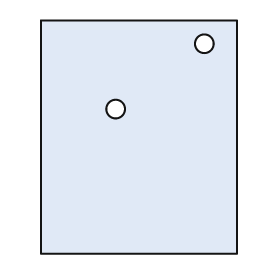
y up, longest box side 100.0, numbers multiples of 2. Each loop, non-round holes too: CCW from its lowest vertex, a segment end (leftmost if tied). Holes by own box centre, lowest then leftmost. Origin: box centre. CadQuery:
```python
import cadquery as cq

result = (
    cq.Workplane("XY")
    .moveTo(-42.0, -50.0)
    .lineTo(42.0, -50.0)
    .lineTo(42.0, 50.0)
    .lineTo(-42.0, 50.0)
    .close()
    .moveTo(-10.0, 12.0)
    .circle(4.0)
    .moveTo(28.0, 40.0)
    .circle(4.0)
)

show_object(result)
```